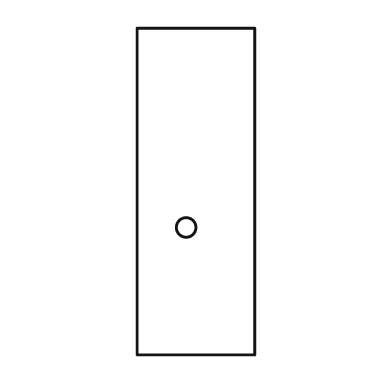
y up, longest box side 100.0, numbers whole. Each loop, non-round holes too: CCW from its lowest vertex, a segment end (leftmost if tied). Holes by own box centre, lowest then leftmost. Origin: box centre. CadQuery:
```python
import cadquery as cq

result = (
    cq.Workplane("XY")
    .moveTo(-18.0, -50.0)
    .lineTo(18.0, -50.0)
    .lineTo(18.0, 50.0)
    .lineTo(-18.0, 50.0)
    .close()
    .moveTo(-3.0, -11.0)
    .circle(3.0)
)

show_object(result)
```